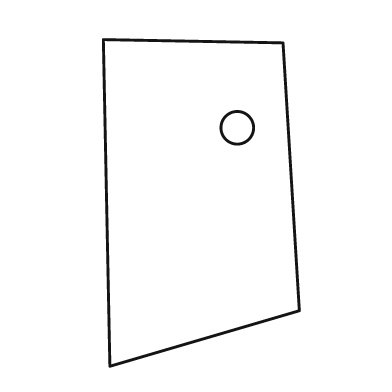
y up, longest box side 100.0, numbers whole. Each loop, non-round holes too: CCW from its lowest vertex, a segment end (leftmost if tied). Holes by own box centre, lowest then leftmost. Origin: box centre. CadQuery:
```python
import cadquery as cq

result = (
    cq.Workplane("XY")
    .moveTo(-28.0, -50.0)
    .lineTo(30.0, -33.0)
    .lineTo(25.0, 49.0)
    .lineTo(-30.0, 50.0)
    .close()
    .moveTo(11.0, 23.0)
    .circle(5.0)
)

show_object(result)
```